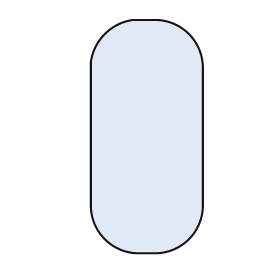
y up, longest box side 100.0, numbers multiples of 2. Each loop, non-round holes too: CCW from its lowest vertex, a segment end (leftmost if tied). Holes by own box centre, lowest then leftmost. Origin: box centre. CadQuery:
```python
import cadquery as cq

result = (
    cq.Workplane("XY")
    .moveTo(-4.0, -50.0)
    .lineTo(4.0, -50.0)
    .threePointArc((18.0, -44.0), (24.0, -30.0))
    .lineTo(24.0, 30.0)
    .threePointArc((18.0, 44.0), (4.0, 50.0))
    .lineTo(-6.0, 50.0)
    .threePointArc((-18.0, 44.0), (-24.0, 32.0))
    .lineTo(-24.0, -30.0)
    .threePointArc((-18.0, -44.0), (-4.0, -50.0))
    .close()
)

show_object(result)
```